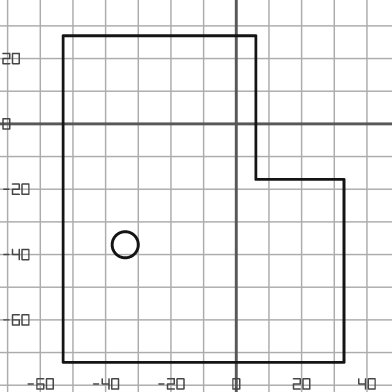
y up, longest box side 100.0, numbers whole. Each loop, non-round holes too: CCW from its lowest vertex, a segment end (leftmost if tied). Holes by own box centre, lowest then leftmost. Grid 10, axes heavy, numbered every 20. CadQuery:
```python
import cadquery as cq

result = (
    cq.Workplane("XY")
    .moveTo(-53.0, -73.0)
    .lineTo(33.0, -73.0)
    .lineTo(33.0, -17.0)
    .lineTo(6.0, -17.0)
    .lineTo(6.0, 27.0)
    .lineTo(-53.0, 27.0)
    .close()
    .moveTo(-34.0, -37.0)
    .circle(4.0)
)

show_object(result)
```